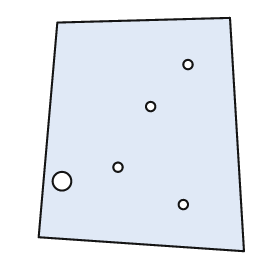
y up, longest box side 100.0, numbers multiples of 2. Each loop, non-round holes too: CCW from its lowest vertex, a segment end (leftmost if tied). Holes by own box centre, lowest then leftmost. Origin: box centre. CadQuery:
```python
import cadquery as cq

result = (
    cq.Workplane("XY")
    .moveTo(44.0, -50.0)
    .lineTo(38.0, 50.0)
    .lineTo(-36.0, 48.0)
    .lineTo(-44.0, -44.0)
    .close()
    .moveTo(18.0, -30.0)
    .circle(2.0)
    .moveTo(-34.0, -20.0)
    .circle(4.0)
    .moveTo(-10.0, -14.0)
    .circle(2.0)
    .moveTo(4.0, 12.0)
    .circle(2.0)
    .moveTo(20.0, 30.0)
    .circle(2.0)
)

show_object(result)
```